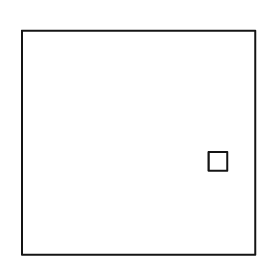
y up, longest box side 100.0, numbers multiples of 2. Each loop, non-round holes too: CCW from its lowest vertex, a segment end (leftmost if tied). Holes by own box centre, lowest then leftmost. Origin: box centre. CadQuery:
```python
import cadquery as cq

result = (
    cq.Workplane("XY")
    .moveTo(-50.0, -48.0)
    .lineTo(50.0, -48.0)
    .lineTo(50.0, 48.0)
    .lineTo(-50.0, 48.0)
    .close()
    .moveTo(30.0, -12.0)
    .lineTo(38.0, -12.0)
    .lineTo(38.0, -4.0)
    .lineTo(30.0, -4.0)
    .close()
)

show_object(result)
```